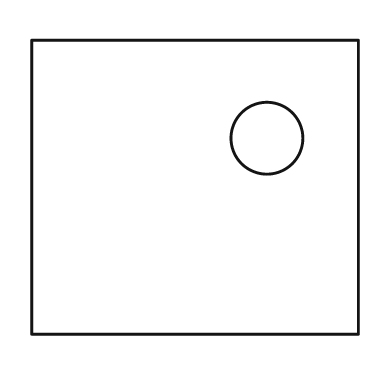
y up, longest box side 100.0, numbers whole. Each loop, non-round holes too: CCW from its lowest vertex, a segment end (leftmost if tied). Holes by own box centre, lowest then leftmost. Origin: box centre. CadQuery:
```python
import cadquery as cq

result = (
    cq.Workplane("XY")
    .moveTo(-50.0, -45.0)
    .lineTo(50.0, -45.0)
    .lineTo(50.0, 45.0)
    .lineTo(-50.0, 45.0)
    .close()
    .moveTo(22.0, 15.0)
    .circle(11.0)
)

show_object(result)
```